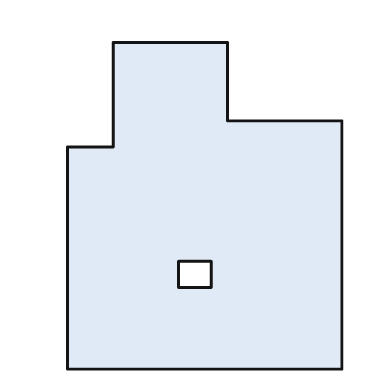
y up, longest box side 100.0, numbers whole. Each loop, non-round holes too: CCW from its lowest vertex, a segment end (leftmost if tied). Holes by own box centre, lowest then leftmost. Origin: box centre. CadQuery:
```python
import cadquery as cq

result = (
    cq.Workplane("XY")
    .moveTo(-42.0, -50.0)
    .lineTo(42.0, -50.0)
    .lineTo(42.0, 26.0)
    .lineTo(7.0, 26.0)
    .lineTo(7.0, 50.0)
    .lineTo(-28.0, 50.0)
    .lineTo(-28.0, 18.0)
    .lineTo(-42.0, 18.0)
    .close()
    .moveTo(-8.0, -25.0)
    .lineTo(2.0, -25.0)
    .lineTo(2.0, -17.0)
    .lineTo(-8.0, -17.0)
    .close()
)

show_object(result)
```